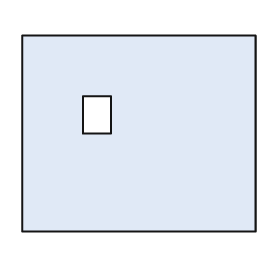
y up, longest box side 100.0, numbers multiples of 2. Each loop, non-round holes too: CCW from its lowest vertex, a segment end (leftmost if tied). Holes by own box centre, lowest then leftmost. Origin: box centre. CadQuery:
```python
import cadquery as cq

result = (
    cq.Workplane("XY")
    .moveTo(-50.0, -42.0)
    .lineTo(50.0, -42.0)
    .lineTo(50.0, 42.0)
    .lineTo(-50.0, 42.0)
    .close()
    .moveTo(-24.0, 0.0)
    .lineTo(-12.0, 0.0)
    .lineTo(-12.0, 16.0)
    .lineTo(-24.0, 16.0)
    .close()
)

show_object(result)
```